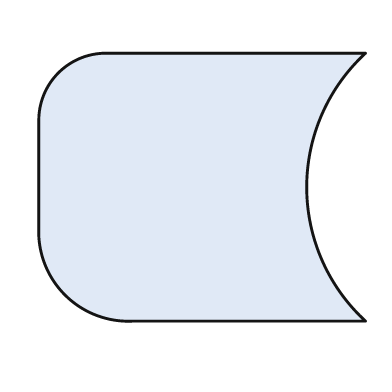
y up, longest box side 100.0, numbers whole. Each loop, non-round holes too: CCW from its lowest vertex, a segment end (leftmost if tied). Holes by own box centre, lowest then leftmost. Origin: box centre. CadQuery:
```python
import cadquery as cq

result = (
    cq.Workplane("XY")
    .moveTo(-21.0, -41.0)
    .lineTo(50.0, -41.0)
    .threePointArc((32.0, 0.0), (50.0, 41.0))
    .lineTo(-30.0, 41.0)
    .threePointArc((-44.0, 35.0), (-50.0, 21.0))
    .lineTo(-50.0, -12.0)
    .threePointArc((-42.0, -33.0), (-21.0, -41.0))
    .close()
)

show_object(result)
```